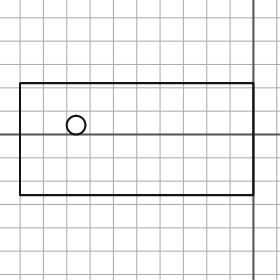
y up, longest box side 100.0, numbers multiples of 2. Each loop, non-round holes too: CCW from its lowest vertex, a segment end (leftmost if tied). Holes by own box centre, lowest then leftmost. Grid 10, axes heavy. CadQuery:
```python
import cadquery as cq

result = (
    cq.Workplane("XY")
    .moveTo(-100.0, -26.0)
    .lineTo(0.0, -26.0)
    .lineTo(0.0, 22.0)
    .lineTo(-100.0, 22.0)
    .close()
    .moveTo(-76.0, 4.0)
    .circle(4.0)
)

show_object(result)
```